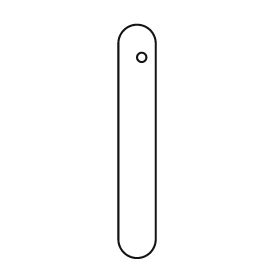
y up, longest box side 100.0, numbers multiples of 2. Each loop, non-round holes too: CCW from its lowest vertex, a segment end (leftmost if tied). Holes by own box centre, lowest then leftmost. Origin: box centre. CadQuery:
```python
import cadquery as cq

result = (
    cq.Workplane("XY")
    .moveTo(-8.0, -42.0)
    .threePointArc((0.0, -50.0), (8.0, -42.0))
    .lineTo(8.0, 42.0)
    .threePointArc((0.0, 50.0), (-8.0, 42.0))
    .close()
    .moveTo(2.0, 36.0)
    .circle(2.0)
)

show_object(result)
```